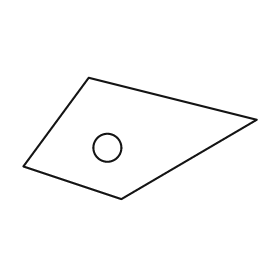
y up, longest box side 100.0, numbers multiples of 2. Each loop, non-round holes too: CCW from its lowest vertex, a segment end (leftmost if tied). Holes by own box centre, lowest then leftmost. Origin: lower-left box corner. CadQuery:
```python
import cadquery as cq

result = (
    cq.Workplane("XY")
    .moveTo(42.0, 0.0)
    .lineTo(100.0, 34.0)
    .lineTo(28.0, 52.0)
    .lineTo(0.0, 14.0)
    .close()
    .moveTo(36.0, 22.0)
    .circle(6.0)
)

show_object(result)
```